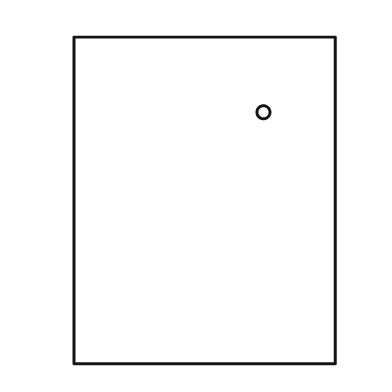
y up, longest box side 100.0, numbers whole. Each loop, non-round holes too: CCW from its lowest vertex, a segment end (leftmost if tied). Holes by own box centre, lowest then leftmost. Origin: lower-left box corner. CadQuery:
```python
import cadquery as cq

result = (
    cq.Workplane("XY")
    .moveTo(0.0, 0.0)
    .lineTo(80.0, 0.0)
    .lineTo(80.0, 100.0)
    .lineTo(0.0, 100.0)
    .close()
    .moveTo(58.0, 77.0)
    .circle(2.0)
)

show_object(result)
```